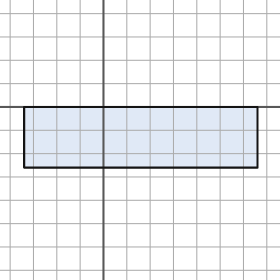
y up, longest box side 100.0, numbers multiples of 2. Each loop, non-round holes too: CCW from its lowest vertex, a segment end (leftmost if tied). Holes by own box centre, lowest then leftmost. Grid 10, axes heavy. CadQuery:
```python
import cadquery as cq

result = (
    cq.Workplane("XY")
    .moveTo(-34.0, -26.0)
    .lineTo(66.0, -26.0)
    .lineTo(66.0, 0.0)
    .lineTo(-34.0, 0.0)
    .close()
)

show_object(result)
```